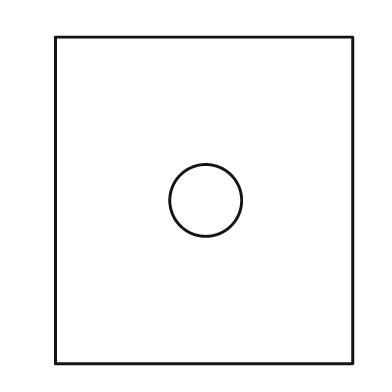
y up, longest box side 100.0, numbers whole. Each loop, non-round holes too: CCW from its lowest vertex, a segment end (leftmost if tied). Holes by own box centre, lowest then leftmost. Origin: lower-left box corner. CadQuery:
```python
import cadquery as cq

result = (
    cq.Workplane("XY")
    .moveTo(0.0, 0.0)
    .lineTo(91.0, 0.0)
    .lineTo(91.0, 100.0)
    .lineTo(0.0, 100.0)
    .close()
    .moveTo(46.0, 50.0)
    .circle(11.0)
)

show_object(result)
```